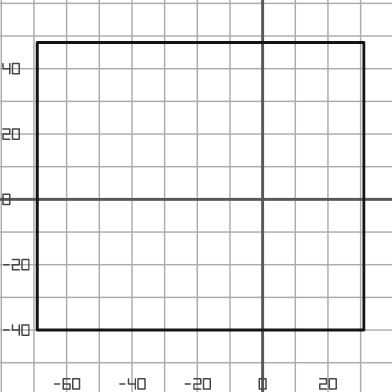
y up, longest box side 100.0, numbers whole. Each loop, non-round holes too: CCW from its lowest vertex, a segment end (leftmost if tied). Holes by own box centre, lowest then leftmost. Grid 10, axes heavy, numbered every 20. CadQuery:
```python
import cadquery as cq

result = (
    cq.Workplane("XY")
    .moveTo(-69.0, -40.0)
    .lineTo(31.0, -40.0)
    .lineTo(31.0, 48.0)
    .lineTo(-69.0, 48.0)
    .close()
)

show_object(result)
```